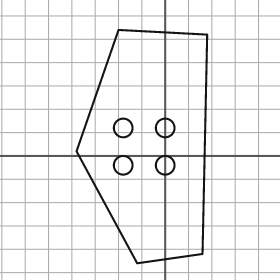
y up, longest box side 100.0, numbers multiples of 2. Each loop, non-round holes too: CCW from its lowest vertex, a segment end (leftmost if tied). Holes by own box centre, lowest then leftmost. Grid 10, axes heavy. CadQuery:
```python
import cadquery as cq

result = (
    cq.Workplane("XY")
    .moveTo(-12.0, -46.0)
    .lineTo(16.0, -42.0)
    .lineTo(18.0, 52.0)
    .lineTo(-20.0, 54.0)
    .lineTo(-38.0, 2.0)
    .close()
    .moveTo(-18.0, -4.0)
    .circle(4.0)
    .moveTo(0.0, -4.0)
    .circle(4.0)
    .moveTo(-18.0, 12.0)
    .circle(4.0)
    .moveTo(0.0, 12.0)
    .circle(4.0)
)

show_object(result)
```